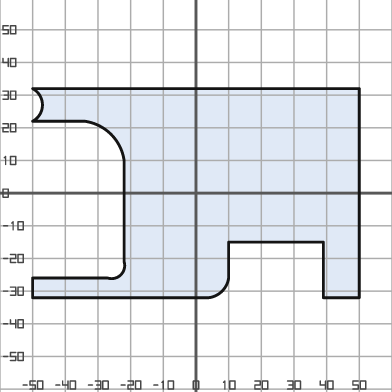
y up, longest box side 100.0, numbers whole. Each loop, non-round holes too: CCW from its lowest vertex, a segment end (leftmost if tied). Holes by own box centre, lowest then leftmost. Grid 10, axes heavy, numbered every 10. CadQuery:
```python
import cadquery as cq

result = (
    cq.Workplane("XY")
    .moveTo(-50.0, -32.0)
    .lineTo(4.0, -32.0)
    .threePointArc((8.0, -30.0), (10.0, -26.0))
    .lineTo(10.0, -15.0)
    .lineTo(39.0, -15.0)
    .lineTo(39.0, -32.0)
    .lineTo(50.0, -32.0)
    .lineTo(50.0, 32.0)
    .lineTo(-50.0, 32.0)
    .threePointArc((-47.0, 27.0), (-50.0, 22.0))
    .lineTo(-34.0, 22.0)
    .threePointArc((-26.0, 18.0), (-22.0, 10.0))
    .lineTo(-22.0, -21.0)
    .threePointArc((-23.0, -25.0), (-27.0, -26.0))
    .lineTo(-50.0, -26.0)
    .close()
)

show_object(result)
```